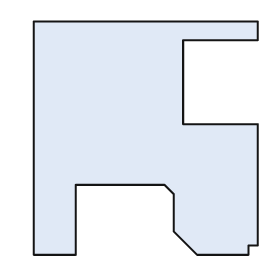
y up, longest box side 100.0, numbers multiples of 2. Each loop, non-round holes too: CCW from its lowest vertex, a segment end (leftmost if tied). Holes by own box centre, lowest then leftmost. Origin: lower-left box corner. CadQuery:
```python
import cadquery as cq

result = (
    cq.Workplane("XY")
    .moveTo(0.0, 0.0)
    .lineTo(18.0, 0.0)
    .lineTo(18.0, 30.0)
    .lineTo(56.0, 30.0)
    .lineTo(60.0, 26.0)
    .lineTo(60.0, 10.0)
    .lineTo(70.0, 0.0)
    .lineTo(92.0, 0.0)
    .lineTo(92.0, 4.0)
    .lineTo(96.0, 4.0)
    .lineTo(96.0, 56.0)
    .lineTo(64.0, 56.0)
    .lineTo(64.0, 92.0)
    .lineTo(96.0, 92.0)
    .lineTo(96.0, 100.0)
    .lineTo(0.0, 100.0)
    .close()
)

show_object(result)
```